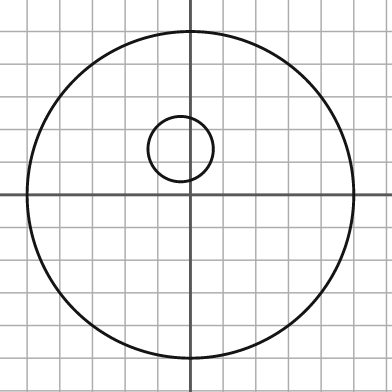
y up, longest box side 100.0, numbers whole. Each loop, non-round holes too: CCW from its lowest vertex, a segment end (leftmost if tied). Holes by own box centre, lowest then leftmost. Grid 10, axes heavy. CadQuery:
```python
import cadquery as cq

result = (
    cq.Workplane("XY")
    .moveTo(0.0, 0.0)
    .circle(50.0)
    .moveTo(-3.0, 14.0)
    .circle(10.0)
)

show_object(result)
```